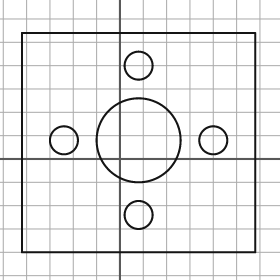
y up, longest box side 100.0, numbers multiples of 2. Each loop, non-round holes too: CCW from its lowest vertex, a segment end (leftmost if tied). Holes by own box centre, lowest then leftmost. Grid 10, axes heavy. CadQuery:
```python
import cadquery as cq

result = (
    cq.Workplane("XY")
    .moveTo(-42.0, -40.0)
    .lineTo(58.0, -40.0)
    .lineTo(58.0, 54.0)
    .lineTo(-42.0, 54.0)
    .close()
    .moveTo(8.0, -24.0)
    .circle(6.0)
    .moveTo(-24.0, 8.0)
    .circle(6.0)
    .moveTo(8.0, 8.0)
    .circle(18.0)
    .moveTo(40.0, 8.0)
    .circle(6.0)
    .moveTo(8.0, 40.0)
    .circle(6.0)
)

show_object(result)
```